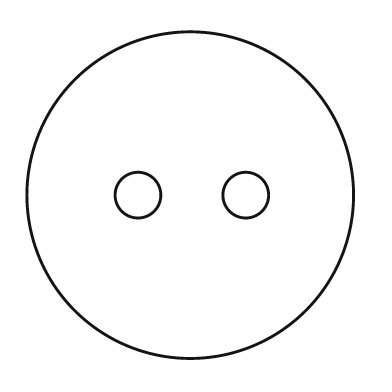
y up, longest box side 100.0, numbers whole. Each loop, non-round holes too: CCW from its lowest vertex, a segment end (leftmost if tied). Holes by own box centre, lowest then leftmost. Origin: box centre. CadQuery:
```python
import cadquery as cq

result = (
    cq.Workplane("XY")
    .moveTo(0.0, 0.0)
    .circle(50.0)
    .moveTo(-16.0, 0.0)
    .circle(7.0)
    .moveTo(17.0, 0.0)
    .circle(7.0)
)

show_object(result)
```